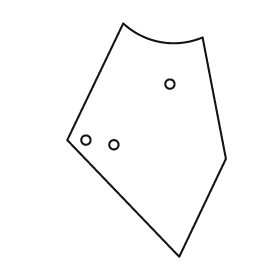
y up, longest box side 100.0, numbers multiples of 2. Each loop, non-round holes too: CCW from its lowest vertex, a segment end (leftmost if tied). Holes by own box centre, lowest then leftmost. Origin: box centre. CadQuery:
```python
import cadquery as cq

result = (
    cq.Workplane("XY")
    .moveTo(14.0, -50.0)
    .lineTo(34.0, -8.0)
    .lineTo(24.0, 44.0)
    .threePointArc((6.0, 42.0), (-10.0, 50.0))
    .lineTo(-34.0, 0.0)
    .close()
    .moveTo(-14.0, -2.0)
    .circle(2.0)
    .moveTo(-26.0, 0.0)
    .circle(2.0)
    .moveTo(10.0, 24.0)
    .circle(2.0)
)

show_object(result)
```